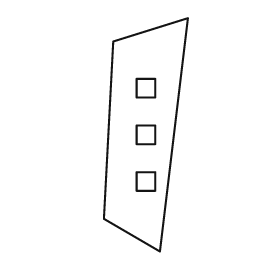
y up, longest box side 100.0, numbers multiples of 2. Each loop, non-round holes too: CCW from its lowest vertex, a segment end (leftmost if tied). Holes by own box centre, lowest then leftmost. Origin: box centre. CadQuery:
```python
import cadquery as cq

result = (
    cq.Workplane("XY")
    .moveTo(6.0, -50.0)
    .lineTo(18.0, 50.0)
    .lineTo(-14.0, 40.0)
    .lineTo(-18.0, -36.0)
    .close()
    .moveTo(-4.0, -24.0)
    .lineTo(4.0, -24.0)
    .lineTo(4.0, -16.0)
    .lineTo(-4.0, -16.0)
    .close()
    .moveTo(-4.0, -4.0)
    .lineTo(4.0, -4.0)
    .lineTo(4.0, 4.0)
    .lineTo(-4.0, 4.0)
    .close()
    .moveTo(-4.0, 16.0)
    .lineTo(4.0, 16.0)
    .lineTo(4.0, 24.0)
    .lineTo(-4.0, 24.0)
    .close()
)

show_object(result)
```